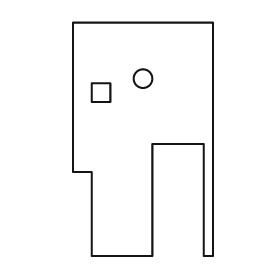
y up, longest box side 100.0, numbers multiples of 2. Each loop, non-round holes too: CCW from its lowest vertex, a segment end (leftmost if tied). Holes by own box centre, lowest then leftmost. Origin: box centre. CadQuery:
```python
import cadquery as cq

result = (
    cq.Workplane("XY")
    .moveTo(-22.0, -50.0)
    .lineTo(4.0, -50.0)
    .lineTo(4.0, -2.0)
    .lineTo(26.0, -2.0)
    .lineTo(26.0, -50.0)
    .lineTo(30.0, -50.0)
    .lineTo(30.0, 50.0)
    .lineTo(-30.0, 50.0)
    .lineTo(-30.0, -14.0)
    .lineTo(-22.0, -14.0)
    .close()
    .moveTo(-22.0, 16.0)
    .lineTo(-14.0, 16.0)
    .lineTo(-14.0, 24.0)
    .lineTo(-22.0, 24.0)
    .close()
    .moveTo(0.0, 26.0)
    .circle(4.0)
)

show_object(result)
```